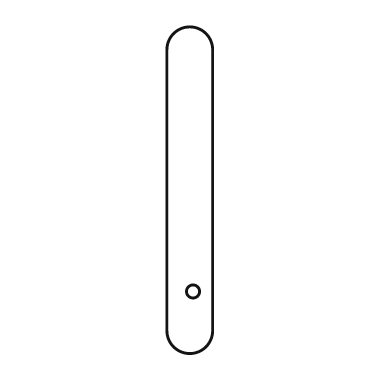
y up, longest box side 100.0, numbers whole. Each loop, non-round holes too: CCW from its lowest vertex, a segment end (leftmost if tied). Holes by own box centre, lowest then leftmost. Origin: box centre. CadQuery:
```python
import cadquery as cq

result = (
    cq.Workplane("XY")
    .moveTo(-7.0, -43.0)
    .threePointArc((0.0, -50.0), (7.0, -43.0))
    .lineTo(7.0, 43.0)
    .threePointArc((0.0, 50.0), (-7.0, 43.0))
    .close()
    .moveTo(1.0, -31.0)
    .circle(2.0)
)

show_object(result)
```